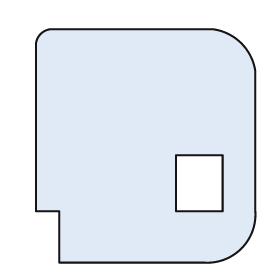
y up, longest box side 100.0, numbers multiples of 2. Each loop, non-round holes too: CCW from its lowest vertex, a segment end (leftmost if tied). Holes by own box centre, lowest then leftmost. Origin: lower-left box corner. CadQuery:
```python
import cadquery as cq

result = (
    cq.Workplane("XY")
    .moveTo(10.0, 0.0)
    .lineTo(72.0, 0.0)
    .threePointArc((88.0, 6.0), (94.0, 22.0))
    .lineTo(94.0, 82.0)
    .threePointArc((88.0, 94.0), (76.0, 100.0))
    .lineTo(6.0, 100.0)
    .threePointArc((2.0, 98.0), (0.0, 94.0))
    .lineTo(0.0, 22.0)
    .lineTo(10.0, 22.0)
    .close()
    .moveTo(60.0, 22.0)
    .lineTo(80.0, 22.0)
    .lineTo(80.0, 46.0)
    .lineTo(60.0, 46.0)
    .close()
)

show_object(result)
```